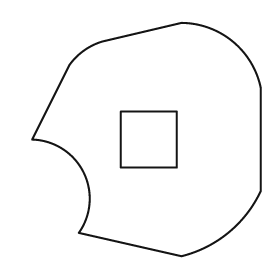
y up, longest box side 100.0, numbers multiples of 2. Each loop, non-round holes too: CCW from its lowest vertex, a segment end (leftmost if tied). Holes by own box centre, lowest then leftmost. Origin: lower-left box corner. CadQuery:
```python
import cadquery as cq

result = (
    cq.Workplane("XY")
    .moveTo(64.0, 0.0)
    .threePointArc((84.0, 10.0), (98.0, 28.0))
    .lineTo(98.0, 72.0)
    .threePointArc((86.0, 92.0), (64.0, 100.0))
    .lineTo(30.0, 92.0)
    .threePointArc((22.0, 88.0), (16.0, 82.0))
    .lineTo(0.0, 50.0)
    .threePointArc((22.0, 36.0), (20.0, 10.0))
    .close()
    .moveTo(38.0, 38.0)
    .lineTo(62.0, 38.0)
    .lineTo(62.0, 62.0)
    .lineTo(38.0, 62.0)
    .close()
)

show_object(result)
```